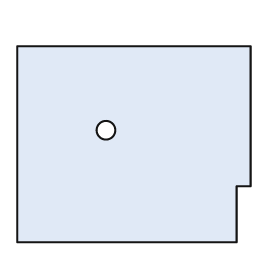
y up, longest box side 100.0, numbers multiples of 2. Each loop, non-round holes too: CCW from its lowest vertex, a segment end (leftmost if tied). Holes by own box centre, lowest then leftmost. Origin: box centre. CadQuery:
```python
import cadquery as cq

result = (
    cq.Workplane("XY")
    .moveTo(-50.0, -42.0)
    .lineTo(44.0, -42.0)
    .lineTo(44.0, -18.0)
    .lineTo(50.0, -18.0)
    .lineTo(50.0, 42.0)
    .lineTo(-50.0, 42.0)
    .close()
    .moveTo(-12.0, 6.0)
    .circle(4.0)
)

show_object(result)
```